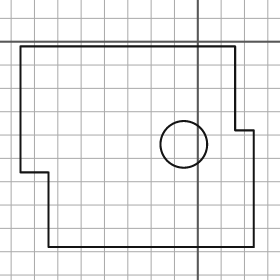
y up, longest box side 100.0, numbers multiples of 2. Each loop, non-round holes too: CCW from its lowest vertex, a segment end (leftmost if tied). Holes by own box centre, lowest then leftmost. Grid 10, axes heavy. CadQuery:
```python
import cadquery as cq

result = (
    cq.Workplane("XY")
    .moveTo(-64.0, -88.0)
    .lineTo(24.0, -88.0)
    .lineTo(24.0, -38.0)
    .lineTo(16.0, -38.0)
    .lineTo(16.0, -2.0)
    .lineTo(-76.0, -2.0)
    .lineTo(-76.0, -56.0)
    .lineTo(-64.0, -56.0)
    .close()
    .moveTo(-6.0, -44.0)
    .circle(10.0)
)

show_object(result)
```